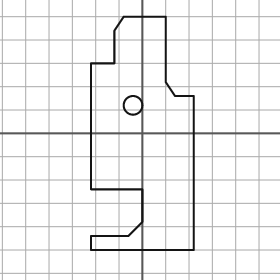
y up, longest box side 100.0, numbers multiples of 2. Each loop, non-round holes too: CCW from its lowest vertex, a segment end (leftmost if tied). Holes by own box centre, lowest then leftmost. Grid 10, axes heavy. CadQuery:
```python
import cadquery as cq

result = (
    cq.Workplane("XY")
    .moveTo(-22.0, -50.0)
    .lineTo(22.0, -50.0)
    .lineTo(22.0, 16.0)
    .lineTo(14.0, 16.0)
    .lineTo(10.0, 22.0)
    .lineTo(10.0, 50.0)
    .lineTo(-8.0, 50.0)
    .lineTo(-12.0, 44.0)
    .lineTo(-12.0, 30.0)
    .lineTo(-22.0, 30.0)
    .lineTo(-22.0, -24.0)
    .lineTo(0.0, -24.0)
    .lineTo(0.0, -38.0)
    .lineTo(-6.0, -44.0)
    .lineTo(-22.0, -44.0)
    .close()
    .moveTo(-4.0, 12.0)
    .circle(4.0)
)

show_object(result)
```